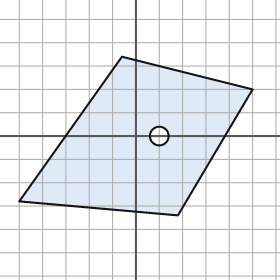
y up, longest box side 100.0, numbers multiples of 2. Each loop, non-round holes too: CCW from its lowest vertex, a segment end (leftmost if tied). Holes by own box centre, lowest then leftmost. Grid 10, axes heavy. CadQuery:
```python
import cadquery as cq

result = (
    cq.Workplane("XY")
    .moveTo(18.0, -34.0)
    .lineTo(50.0, 20.0)
    .lineTo(-6.0, 34.0)
    .lineTo(-50.0, -28.0)
    .close()
    .moveTo(10.0, 0.0)
    .circle(4.0)
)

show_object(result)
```